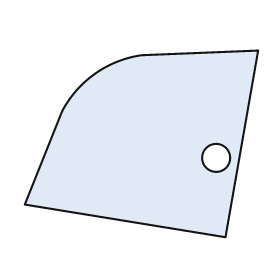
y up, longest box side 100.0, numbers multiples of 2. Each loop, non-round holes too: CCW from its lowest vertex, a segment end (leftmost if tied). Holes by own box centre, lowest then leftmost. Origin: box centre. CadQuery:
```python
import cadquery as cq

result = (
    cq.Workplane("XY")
    .moveTo(36.0, -40.0)
    .lineTo(50.0, 40.0)
    .lineTo(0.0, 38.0)
    .threePointArc((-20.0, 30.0), (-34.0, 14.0))
    .lineTo(-50.0, -26.0)
    .close()
    .moveTo(32.0, -6.0)
    .circle(6.0)
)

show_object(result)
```